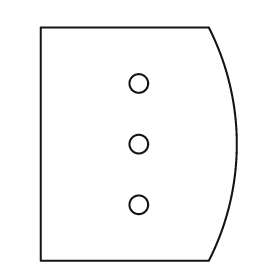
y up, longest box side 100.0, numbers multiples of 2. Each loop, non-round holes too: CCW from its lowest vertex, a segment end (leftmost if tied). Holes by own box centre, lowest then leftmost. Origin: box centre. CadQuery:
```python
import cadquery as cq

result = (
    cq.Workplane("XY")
    .moveTo(-42.0, -50.0)
    .lineTo(30.0, -50.0)
    .threePointArc((42.0, 0.0), (30.0, 50.0))
    .lineTo(-42.0, 50.0)
    .close()
    .moveTo(0.0, -26.0)
    .circle(4.0)
    .moveTo(0.0, 0.0)
    .circle(4.0)
    .moveTo(0.0, 26.0)
    .circle(4.0)
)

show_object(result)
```